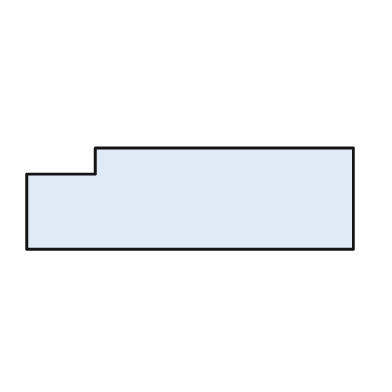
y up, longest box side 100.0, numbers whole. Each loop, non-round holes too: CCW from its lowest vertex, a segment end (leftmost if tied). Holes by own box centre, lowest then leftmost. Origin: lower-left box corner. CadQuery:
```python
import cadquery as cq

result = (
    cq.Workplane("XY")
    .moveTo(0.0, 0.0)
    .lineTo(100.0, 0.0)
    .lineTo(100.0, 31.0)
    .lineTo(21.0, 31.0)
    .lineTo(21.0, 23.0)
    .lineTo(0.0, 23.0)
    .close()
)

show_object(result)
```